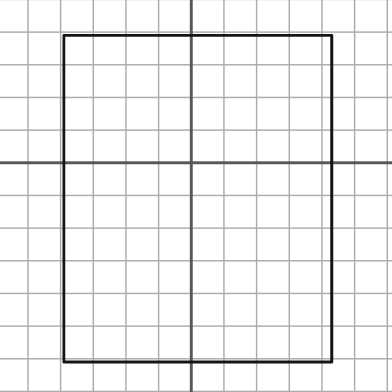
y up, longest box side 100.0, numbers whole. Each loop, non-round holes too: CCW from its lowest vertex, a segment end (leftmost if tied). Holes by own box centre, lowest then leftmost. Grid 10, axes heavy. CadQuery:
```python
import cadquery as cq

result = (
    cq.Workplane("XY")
    .moveTo(-39.0, -61.0)
    .lineTo(43.0, -61.0)
    .lineTo(43.0, 39.0)
    .lineTo(-39.0, 39.0)
    .close()
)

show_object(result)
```